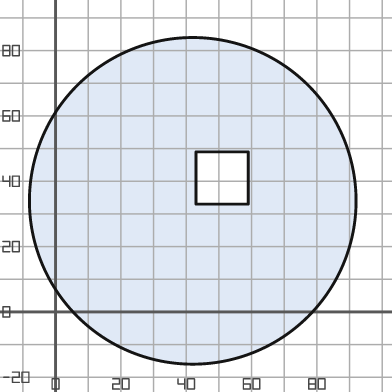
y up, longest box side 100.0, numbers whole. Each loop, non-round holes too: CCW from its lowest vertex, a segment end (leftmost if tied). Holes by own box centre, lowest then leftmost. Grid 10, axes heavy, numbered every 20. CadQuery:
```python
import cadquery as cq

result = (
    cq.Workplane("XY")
    .moveTo(42.0, 34.0)
    .circle(50.0)
    .moveTo(43.0, 33.0)
    .lineTo(59.0, 33.0)
    .lineTo(59.0, 49.0)
    .lineTo(43.0, 49.0)
    .close()
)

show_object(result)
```